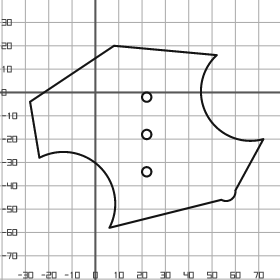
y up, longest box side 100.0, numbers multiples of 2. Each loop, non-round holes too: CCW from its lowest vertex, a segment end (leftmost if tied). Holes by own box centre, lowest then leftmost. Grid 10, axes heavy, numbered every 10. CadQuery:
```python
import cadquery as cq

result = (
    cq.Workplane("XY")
    .moveTo(6.0, -58.0)
    .lineTo(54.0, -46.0)
    .threePointArc((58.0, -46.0), (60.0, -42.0))
    .lineTo(72.0, -20.0)
    .threePointArc((48.0, -10.0), (52.0, 16.0))
    .lineTo(8.0, 20.0)
    .lineTo(-28.0, -4.0)
    .lineTo(-24.0, -28.0)
    .threePointArc((2.0, -32.0), (6.0, -58.0))
    .close()
    .moveTo(22.0, -34.0)
    .circle(2.0)
    .moveTo(22.0, -18.0)
    .circle(2.0)
    .moveTo(22.0, -2.0)
    .circle(2.0)
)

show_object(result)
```